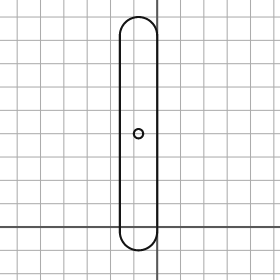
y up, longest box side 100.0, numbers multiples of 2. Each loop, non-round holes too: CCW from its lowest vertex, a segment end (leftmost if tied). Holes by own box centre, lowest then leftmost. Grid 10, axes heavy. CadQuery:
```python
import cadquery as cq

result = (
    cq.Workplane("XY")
    .moveTo(-16.0, -2.0)
    .threePointArc((-8.0, -10.0), (0.0, -2.0))
    .lineTo(0.0, 82.0)
    .threePointArc((-8.0, 90.0), (-16.0, 82.0))
    .close()
    .moveTo(-8.0, 40.0)
    .circle(2.0)
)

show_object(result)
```